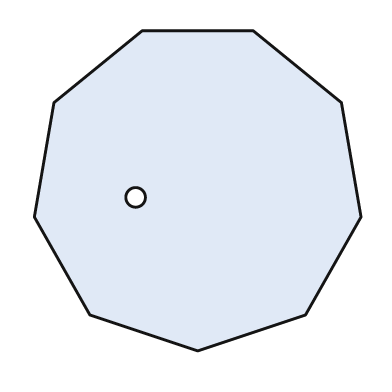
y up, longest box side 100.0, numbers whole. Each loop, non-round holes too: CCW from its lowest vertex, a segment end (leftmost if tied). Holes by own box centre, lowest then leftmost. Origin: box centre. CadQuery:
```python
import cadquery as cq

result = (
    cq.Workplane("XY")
    .moveTo(0.0, -49.0)
    .lineTo(33.0, -38.0)
    .lineTo(50.0, -8.0)
    .lineTo(44.0, 27.0)
    .lineTo(17.0, 49.0)
    .lineTo(-17.0, 49.0)
    .lineTo(-44.0, 27.0)
    .lineTo(-50.0, -8.0)
    .lineTo(-33.0, -38.0)
    .close()
    .moveTo(-19.0, -2.0)
    .circle(3.0)
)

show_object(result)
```